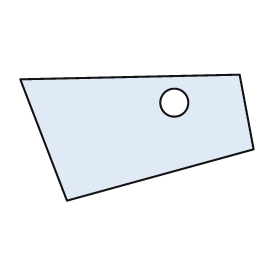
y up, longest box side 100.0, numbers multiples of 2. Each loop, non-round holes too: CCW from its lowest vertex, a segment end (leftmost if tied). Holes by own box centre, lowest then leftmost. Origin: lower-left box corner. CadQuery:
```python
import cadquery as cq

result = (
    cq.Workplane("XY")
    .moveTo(20.0, 0.0)
    .lineTo(100.0, 22.0)
    .lineTo(94.0, 54.0)
    .lineTo(0.0, 52.0)
    .close()
    .moveTo(66.0, 42.0)
    .circle(6.0)
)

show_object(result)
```